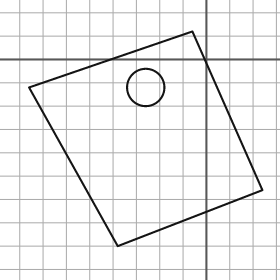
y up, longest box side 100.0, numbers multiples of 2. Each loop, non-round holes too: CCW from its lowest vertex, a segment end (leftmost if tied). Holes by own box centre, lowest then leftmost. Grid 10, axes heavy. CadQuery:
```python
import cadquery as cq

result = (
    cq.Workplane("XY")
    .moveTo(-38.0, -80.0)
    .lineTo(24.0, -56.0)
    .lineTo(-6.0, 12.0)
    .lineTo(-76.0, -12.0)
    .close()
    .moveTo(-26.0, -12.0)
    .circle(8.0)
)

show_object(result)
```